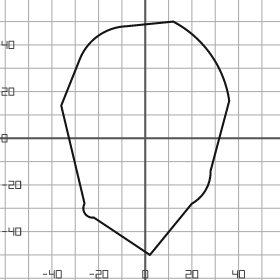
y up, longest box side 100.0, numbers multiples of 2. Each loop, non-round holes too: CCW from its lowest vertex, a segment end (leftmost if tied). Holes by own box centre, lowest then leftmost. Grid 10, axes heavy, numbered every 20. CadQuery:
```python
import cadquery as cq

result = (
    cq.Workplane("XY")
    .moveTo(2.0, -50.0)
    .lineTo(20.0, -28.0)
    .threePointArc((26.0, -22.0), (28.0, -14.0))
    .lineTo(36.0, 16.0)
    .threePointArc((28.0, 36.0), (12.0, 50.0))
    .lineTo(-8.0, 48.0)
    .threePointArc((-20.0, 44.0), (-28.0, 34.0))
    .lineTo(-36.0, 14.0)
    .lineTo(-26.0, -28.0)
    .threePointArc((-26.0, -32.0), (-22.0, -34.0))
    .close()
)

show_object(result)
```